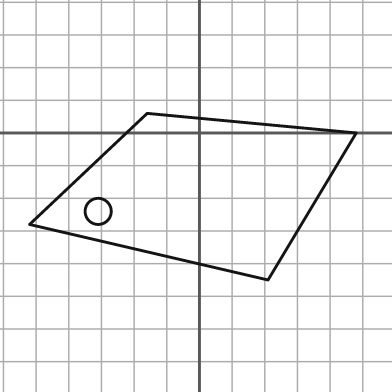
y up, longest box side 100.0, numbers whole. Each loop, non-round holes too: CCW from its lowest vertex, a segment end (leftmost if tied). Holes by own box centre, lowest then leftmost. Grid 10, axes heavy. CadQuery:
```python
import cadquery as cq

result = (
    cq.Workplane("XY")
    .moveTo(21.0, -45.0)
    .lineTo(48.0, 0.0)
    .lineTo(-16.0, 6.0)
    .lineTo(-52.0, -28.0)
    .close()
    .moveTo(-31.0, -24.0)
    .circle(4.0)
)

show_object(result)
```